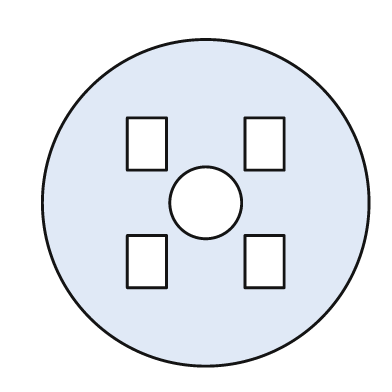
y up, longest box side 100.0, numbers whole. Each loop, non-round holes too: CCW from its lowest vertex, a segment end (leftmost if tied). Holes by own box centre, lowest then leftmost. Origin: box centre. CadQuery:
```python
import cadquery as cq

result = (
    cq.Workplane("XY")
    .moveTo(0.0, 0.0)
    .circle(50.0)
    .moveTo(-24.0, -26.0)
    .lineTo(-12.0, -26.0)
    .lineTo(-12.0, -10.0)
    .lineTo(-24.0, -10.0)
    .close()
    .moveTo(12.0, -26.0)
    .lineTo(24.0, -26.0)
    .lineTo(24.0, -10.0)
    .lineTo(12.0, -10.0)
    .close()
    .moveTo(0.0, 0.0)
    .circle(11.0)
    .moveTo(-24.0, 10.0)
    .lineTo(-12.0, 10.0)
    .lineTo(-12.0, 26.0)
    .lineTo(-24.0, 26.0)
    .close()
    .moveTo(12.0, 10.0)
    .lineTo(24.0, 10.0)
    .lineTo(24.0, 26.0)
    .lineTo(12.0, 26.0)
    .close()
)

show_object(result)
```